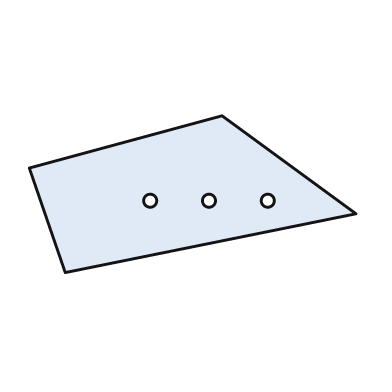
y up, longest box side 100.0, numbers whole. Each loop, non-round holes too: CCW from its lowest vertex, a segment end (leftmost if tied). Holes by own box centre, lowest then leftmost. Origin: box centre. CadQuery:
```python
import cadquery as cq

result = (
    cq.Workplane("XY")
    .moveTo(-39.0, -24.0)
    .lineTo(50.0, -6.0)
    .lineTo(9.0, 24.0)
    .lineTo(-50.0, 8.0)
    .close()
    .moveTo(-13.0, -2.0)
    .circle(2.0)
    .moveTo(5.0, -2.0)
    .circle(2.0)
    .moveTo(23.0, -2.0)
    .circle(2.0)
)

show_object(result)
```